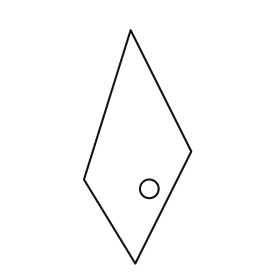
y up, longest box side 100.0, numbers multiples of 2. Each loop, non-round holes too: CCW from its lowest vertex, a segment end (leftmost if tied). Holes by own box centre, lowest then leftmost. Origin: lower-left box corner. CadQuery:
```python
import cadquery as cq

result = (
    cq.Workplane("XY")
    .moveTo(22.0, 0.0)
    .lineTo(46.0, 48.0)
    .lineTo(20.0, 100.0)
    .lineTo(0.0, 36.0)
    .close()
    .moveTo(28.0, 32.0)
    .circle(4.0)
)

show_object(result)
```